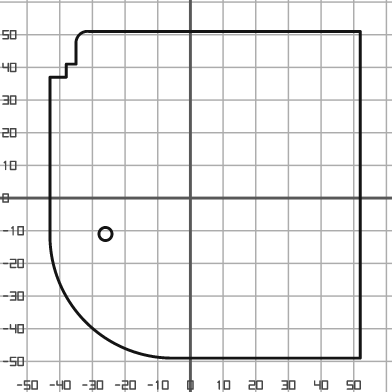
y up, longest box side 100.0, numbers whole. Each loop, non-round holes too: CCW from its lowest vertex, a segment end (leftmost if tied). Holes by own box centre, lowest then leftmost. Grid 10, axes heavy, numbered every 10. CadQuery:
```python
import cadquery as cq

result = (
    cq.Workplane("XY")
    .moveTo(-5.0, -49.0)
    .lineTo(52.0, -49.0)
    .lineTo(52.0, 51.0)
    .lineTo(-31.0, 51.0)
    .threePointArc((-34.0, 50.0), (-35.0, 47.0))
    .lineTo(-35.0, 41.0)
    .lineTo(-38.0, 41.0)
    .lineTo(-38.0, 37.0)
    .lineTo(-43.0, 37.0)
    .lineTo(-43.0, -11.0)
    .threePointArc((-32.0, -38.0), (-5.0, -49.0))
    .close()
    .moveTo(-26.0, -11.0)
    .circle(2.0)
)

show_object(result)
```